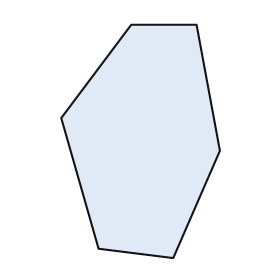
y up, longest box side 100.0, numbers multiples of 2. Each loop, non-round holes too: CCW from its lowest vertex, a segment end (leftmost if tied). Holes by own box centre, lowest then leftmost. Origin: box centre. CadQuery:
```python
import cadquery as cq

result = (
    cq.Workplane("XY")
    .moveTo(14.0, -50.0)
    .lineTo(34.0, -4.0)
    .lineTo(24.0, 50.0)
    .lineTo(-4.0, 50.0)
    .lineTo(-34.0, 10.0)
    .lineTo(-18.0, -46.0)
    .close()
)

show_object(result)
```